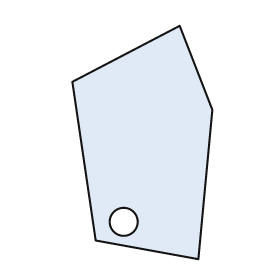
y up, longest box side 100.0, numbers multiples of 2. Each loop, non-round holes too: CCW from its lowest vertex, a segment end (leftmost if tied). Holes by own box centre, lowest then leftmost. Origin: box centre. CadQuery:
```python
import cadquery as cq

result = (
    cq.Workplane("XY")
    .moveTo(24.0, -50.0)
    .lineTo(30.0, 14.0)
    .lineTo(16.0, 50.0)
    .lineTo(-30.0, 26.0)
    .lineTo(-20.0, -42.0)
    .close()
    .moveTo(-8.0, -34.0)
    .circle(6.0)
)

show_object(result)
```